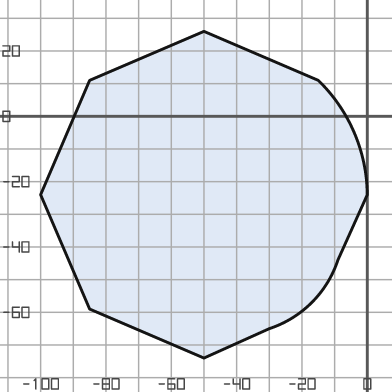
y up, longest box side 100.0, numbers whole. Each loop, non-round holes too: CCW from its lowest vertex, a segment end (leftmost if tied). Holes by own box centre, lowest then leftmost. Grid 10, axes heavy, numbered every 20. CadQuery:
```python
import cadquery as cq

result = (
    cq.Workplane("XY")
    .moveTo(-50.0, -74.0)
    .lineTo(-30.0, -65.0)
    .threePointArc((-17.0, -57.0), (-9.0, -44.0))
    .lineTo(0.0, -24.0)
    .threePointArc((-4.0, -5.0), (-15.0, 11.0))
    .lineTo(-50.0, 26.0)
    .lineTo(-85.0, 11.0)
    .lineTo(-100.0, -24.0)
    .lineTo(-85.0, -59.0)
    .close()
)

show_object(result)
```